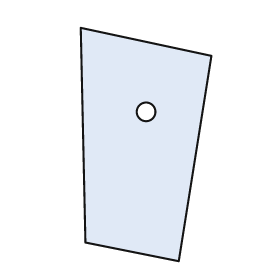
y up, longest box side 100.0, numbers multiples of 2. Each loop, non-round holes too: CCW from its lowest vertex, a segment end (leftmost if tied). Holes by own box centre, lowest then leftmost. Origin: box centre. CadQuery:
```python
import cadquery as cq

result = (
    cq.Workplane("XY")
    .moveTo(14.0, -50.0)
    .lineTo(28.0, 38.0)
    .lineTo(-28.0, 50.0)
    .lineTo(-26.0, -42.0)
    .close()
    .moveTo(0.0, 14.0)
    .circle(4.0)
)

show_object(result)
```